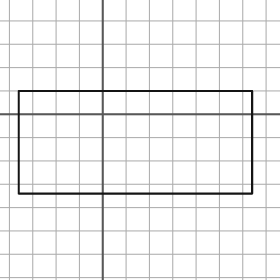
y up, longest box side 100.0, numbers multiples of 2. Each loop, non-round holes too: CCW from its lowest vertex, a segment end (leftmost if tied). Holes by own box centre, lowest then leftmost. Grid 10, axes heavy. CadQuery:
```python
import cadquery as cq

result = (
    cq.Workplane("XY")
    .moveTo(-36.0, -34.0)
    .lineTo(64.0, -34.0)
    .lineTo(64.0, 10.0)
    .lineTo(-36.0, 10.0)
    .close()
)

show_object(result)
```